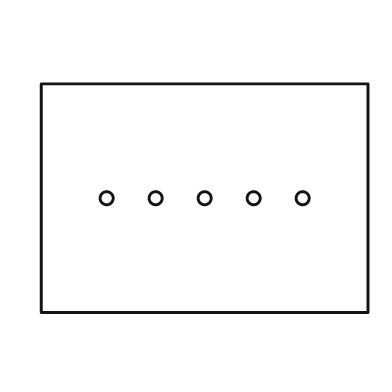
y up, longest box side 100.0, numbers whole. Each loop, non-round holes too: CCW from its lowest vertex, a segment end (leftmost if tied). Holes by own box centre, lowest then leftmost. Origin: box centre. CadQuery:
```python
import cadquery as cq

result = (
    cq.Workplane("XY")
    .moveTo(-50.0, -35.0)
    .lineTo(50.0, -35.0)
    .lineTo(50.0, 35.0)
    .lineTo(-50.0, 35.0)
    .close()
    .moveTo(-30.0, 0.0)
    .circle(2.0)
    .moveTo(-15.0, 0.0)
    .circle(2.0)
    .moveTo(0.0, 0.0)
    .circle(2.0)
    .moveTo(15.0, 0.0)
    .circle(2.0)
    .moveTo(30.0, 0.0)
    .circle(2.0)
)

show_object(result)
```